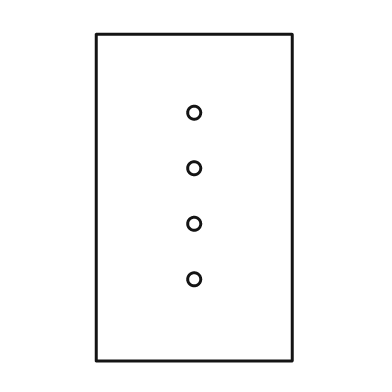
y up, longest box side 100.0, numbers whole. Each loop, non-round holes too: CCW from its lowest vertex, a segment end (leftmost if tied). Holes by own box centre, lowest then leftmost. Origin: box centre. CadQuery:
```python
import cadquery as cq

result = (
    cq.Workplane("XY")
    .moveTo(-30.0, -50.0)
    .lineTo(30.0, -50.0)
    .lineTo(30.0, 50.0)
    .lineTo(-30.0, 50.0)
    .close()
    .moveTo(0.0, -25.0)
    .circle(2.0)
    .moveTo(0.0, -8.0)
    .circle(2.0)
    .moveTo(0.0, 9.0)
    .circle(2.0)
    .moveTo(0.0, 26.0)
    .circle(2.0)
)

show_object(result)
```